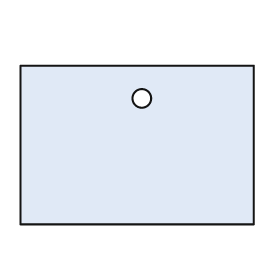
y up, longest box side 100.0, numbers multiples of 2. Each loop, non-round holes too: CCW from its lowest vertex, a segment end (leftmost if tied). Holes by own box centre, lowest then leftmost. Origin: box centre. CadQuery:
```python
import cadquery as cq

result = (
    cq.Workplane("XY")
    .moveTo(-50.0, -34.0)
    .lineTo(50.0, -34.0)
    .lineTo(50.0, 34.0)
    .lineTo(-50.0, 34.0)
    .close()
    .moveTo(2.0, 20.0)
    .circle(4.0)
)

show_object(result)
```